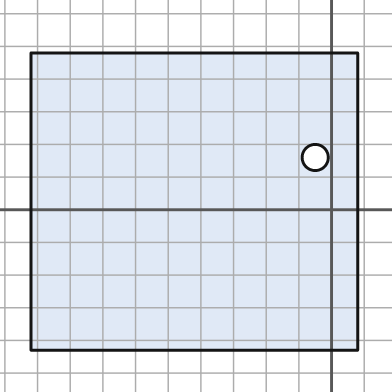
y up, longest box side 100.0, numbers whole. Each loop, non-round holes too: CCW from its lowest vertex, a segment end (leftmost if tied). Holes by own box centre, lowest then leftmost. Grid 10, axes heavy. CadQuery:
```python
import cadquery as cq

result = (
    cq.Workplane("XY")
    .moveTo(-92.0, -43.0)
    .lineTo(8.0, -43.0)
    .lineTo(8.0, 48.0)
    .lineTo(-92.0, 48.0)
    .close()
    .moveTo(-5.0, 16.0)
    .circle(4.0)
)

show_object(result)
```